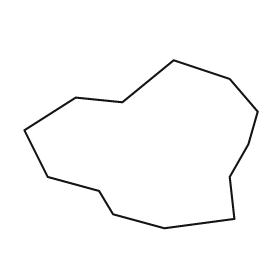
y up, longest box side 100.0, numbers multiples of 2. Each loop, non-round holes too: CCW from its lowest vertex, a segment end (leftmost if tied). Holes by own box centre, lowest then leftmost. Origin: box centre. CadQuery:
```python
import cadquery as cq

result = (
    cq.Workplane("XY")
    .moveTo(10.0, -36.0)
    .lineTo(40.0, -32.0)
    .lineTo(38.0, -14.0)
    .lineTo(46.0, 0.0)
    .lineTo(50.0, 14.0)
    .lineTo(38.0, 28.0)
    .lineTo(14.0, 36.0)
    .lineTo(-8.0, 18.0)
    .lineTo(-28.0, 20.0)
    .lineTo(-50.0, 6.0)
    .lineTo(-40.0, -14.0)
    .lineTo(-18.0, -20.0)
    .lineTo(-12.0, -30.0)
    .close()
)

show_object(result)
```